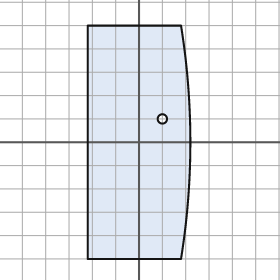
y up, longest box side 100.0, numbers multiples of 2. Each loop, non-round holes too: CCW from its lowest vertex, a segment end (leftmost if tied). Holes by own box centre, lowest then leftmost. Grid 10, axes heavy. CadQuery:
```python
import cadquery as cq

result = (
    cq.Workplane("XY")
    .moveTo(-22.0, -50.0)
    .lineTo(18.0, -50.0)
    .threePointArc((22.0, 0.0), (18.0, 50.0))
    .lineTo(-22.0, 50.0)
    .close()
    .moveTo(10.0, 10.0)
    .circle(2.0)
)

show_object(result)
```